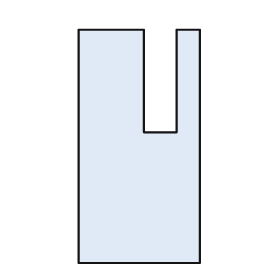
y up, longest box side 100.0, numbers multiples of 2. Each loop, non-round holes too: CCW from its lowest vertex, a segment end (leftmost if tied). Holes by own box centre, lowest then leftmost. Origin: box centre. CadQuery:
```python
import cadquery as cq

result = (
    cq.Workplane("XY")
    .moveTo(-26.0, -50.0)
    .lineTo(26.0, -50.0)
    .lineTo(26.0, 50.0)
    .lineTo(16.0, 50.0)
    .lineTo(16.0, 6.0)
    .lineTo(2.0, 6.0)
    .lineTo(2.0, 50.0)
    .lineTo(-26.0, 50.0)
    .close()
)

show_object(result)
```